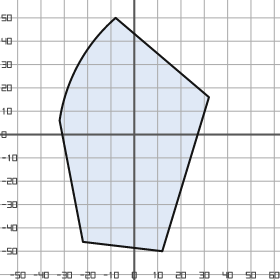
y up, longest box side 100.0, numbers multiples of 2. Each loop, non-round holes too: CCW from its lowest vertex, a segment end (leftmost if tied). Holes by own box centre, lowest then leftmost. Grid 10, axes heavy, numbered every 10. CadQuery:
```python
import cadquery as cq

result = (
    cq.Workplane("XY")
    .moveTo(12.0, -50.0)
    .lineTo(32.0, 16.0)
    .lineTo(-8.0, 50.0)
    .threePointArc((-24.0, 30.0), (-32.0, 6.0))
    .lineTo(-22.0, -46.0)
    .close()
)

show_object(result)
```